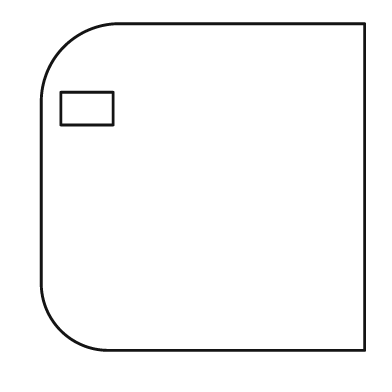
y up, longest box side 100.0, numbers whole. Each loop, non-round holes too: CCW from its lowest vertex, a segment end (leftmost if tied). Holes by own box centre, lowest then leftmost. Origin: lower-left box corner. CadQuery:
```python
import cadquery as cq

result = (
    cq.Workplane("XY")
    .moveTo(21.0, 0.0)
    .lineTo(99.0, 0.0)
    .lineTo(99.0, 100.0)
    .lineTo(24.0, 100.0)
    .threePointArc((7.0, 93.0), (0.0, 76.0))
    .lineTo(0.0, 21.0)
    .threePointArc((6.0, 6.0), (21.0, 0.0))
    .close()
    .moveTo(6.0, 69.0)
    .lineTo(22.0, 69.0)
    .lineTo(22.0, 79.0)
    .lineTo(6.0, 79.0)
    .close()
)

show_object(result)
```